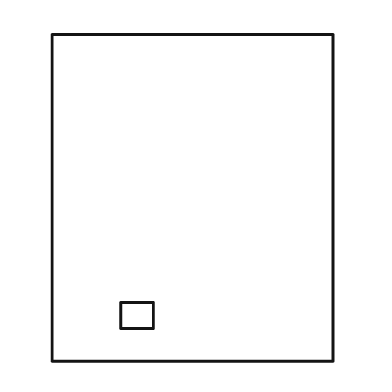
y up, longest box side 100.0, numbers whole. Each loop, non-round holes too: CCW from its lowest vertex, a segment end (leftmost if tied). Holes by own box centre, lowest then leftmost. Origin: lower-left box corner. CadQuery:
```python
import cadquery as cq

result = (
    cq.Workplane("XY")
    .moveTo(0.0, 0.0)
    .lineTo(86.0, 0.0)
    .lineTo(86.0, 100.0)
    .lineTo(0.0, 100.0)
    .close()
    .moveTo(21.0, 10.0)
    .lineTo(31.0, 10.0)
    .lineTo(31.0, 18.0)
    .lineTo(21.0, 18.0)
    .close()
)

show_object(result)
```